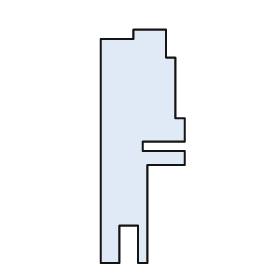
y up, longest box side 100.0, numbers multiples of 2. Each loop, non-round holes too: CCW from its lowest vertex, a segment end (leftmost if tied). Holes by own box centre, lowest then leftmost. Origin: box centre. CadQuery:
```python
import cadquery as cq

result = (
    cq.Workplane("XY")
    .moveTo(-18.0, -50.0)
    .lineTo(-10.0, -50.0)
    .lineTo(-10.0, -34.0)
    .lineTo(-2.0, -34.0)
    .lineTo(-2.0, -50.0)
    .lineTo(2.0, -50.0)
    .lineTo(2.0, -8.0)
    .lineTo(18.0, -8.0)
    .lineTo(18.0, -2.0)
    .lineTo(0.0, -2.0)
    .lineTo(0.0, 2.0)
    .lineTo(18.0, 2.0)
    .lineTo(18.0, 12.0)
    .lineTo(14.0, 12.0)
    .lineTo(14.0, 38.0)
    .lineTo(10.0, 38.0)
    .lineTo(10.0, 50.0)
    .lineTo(-4.0, 50.0)
    .lineTo(-4.0, 46.0)
    .lineTo(-18.0, 46.0)
    .close()
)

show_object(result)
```